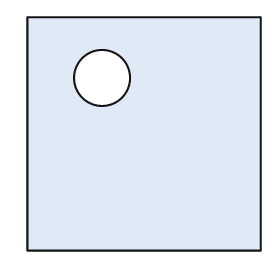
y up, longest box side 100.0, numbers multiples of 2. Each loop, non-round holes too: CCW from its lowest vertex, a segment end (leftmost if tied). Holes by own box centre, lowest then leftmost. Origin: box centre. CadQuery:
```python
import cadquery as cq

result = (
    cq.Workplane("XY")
    .moveTo(-50.0, -50.0)
    .lineTo(50.0, -50.0)
    .lineTo(50.0, 50.0)
    .lineTo(-50.0, 50.0)
    .close()
    .moveTo(-18.0, 24.0)
    .circle(12.0)
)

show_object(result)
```